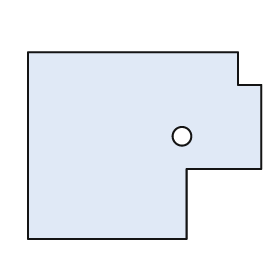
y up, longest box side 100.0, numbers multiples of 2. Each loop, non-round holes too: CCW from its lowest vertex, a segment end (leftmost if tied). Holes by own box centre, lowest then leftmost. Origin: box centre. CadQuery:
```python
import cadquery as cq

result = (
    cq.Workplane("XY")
    .moveTo(-50.0, -40.0)
    .lineTo(18.0, -40.0)
    .lineTo(18.0, -10.0)
    .lineTo(50.0, -10.0)
    .lineTo(50.0, 26.0)
    .lineTo(40.0, 26.0)
    .lineTo(40.0, 40.0)
    .lineTo(-50.0, 40.0)
    .close()
    .moveTo(16.0, 4.0)
    .circle(4.0)
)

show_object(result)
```